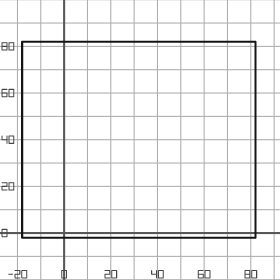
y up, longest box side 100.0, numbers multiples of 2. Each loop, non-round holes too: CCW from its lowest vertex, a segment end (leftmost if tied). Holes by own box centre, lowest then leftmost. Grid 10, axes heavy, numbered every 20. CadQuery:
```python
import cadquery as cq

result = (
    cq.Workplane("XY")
    .moveTo(-18.0, -2.0)
    .lineTo(82.0, -2.0)
    .lineTo(82.0, 82.0)
    .lineTo(-18.0, 82.0)
    .close()
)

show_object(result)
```